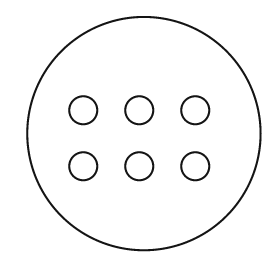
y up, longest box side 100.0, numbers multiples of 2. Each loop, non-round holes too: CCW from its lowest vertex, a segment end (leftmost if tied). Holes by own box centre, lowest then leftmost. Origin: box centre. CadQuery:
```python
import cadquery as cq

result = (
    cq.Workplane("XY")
    .moveTo(0.0, 0.0)
    .circle(50.0)
    .moveTo(-26.0, -14.0)
    .circle(6.0)
    .moveTo(-2.0, -14.0)
    .circle(6.0)
    .moveTo(22.0, -14.0)
    .circle(6.0)
    .moveTo(-26.0, 10.0)
    .circle(6.0)
    .moveTo(-2.0, 10.0)
    .circle(6.0)
    .moveTo(22.0, 10.0)
    .circle(6.0)
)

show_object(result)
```